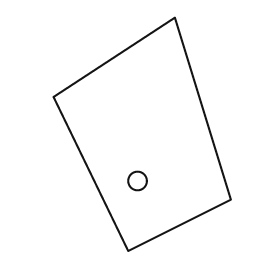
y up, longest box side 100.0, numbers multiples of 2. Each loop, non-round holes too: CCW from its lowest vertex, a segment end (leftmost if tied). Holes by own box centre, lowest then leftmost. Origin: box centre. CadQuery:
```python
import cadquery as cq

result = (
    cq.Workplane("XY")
    .moveTo(-6.0, -50.0)
    .lineTo(38.0, -28.0)
    .lineTo(14.0, 50.0)
    .lineTo(-38.0, 16.0)
    .close()
    .moveTo(-2.0, -20.0)
    .circle(4.0)
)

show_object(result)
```